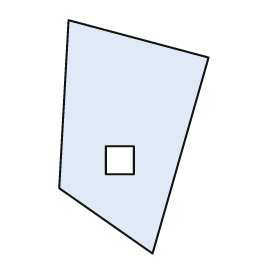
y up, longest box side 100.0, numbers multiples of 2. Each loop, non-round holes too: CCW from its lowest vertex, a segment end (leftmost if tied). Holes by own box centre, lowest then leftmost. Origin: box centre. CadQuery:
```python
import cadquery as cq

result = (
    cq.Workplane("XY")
    .moveTo(8.0, -50.0)
    .lineTo(32.0, 34.0)
    .lineTo(-28.0, 50.0)
    .lineTo(-32.0, -22.0)
    .close()
    .moveTo(-12.0, -16.0)
    .lineTo(0.0, -16.0)
    .lineTo(0.0, -4.0)
    .lineTo(-12.0, -4.0)
    .close()
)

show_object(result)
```